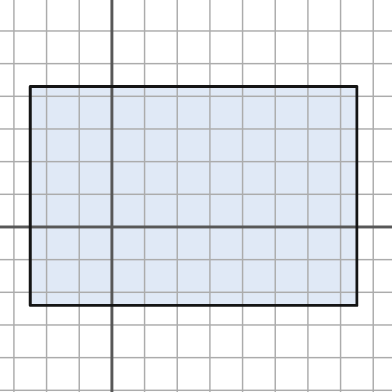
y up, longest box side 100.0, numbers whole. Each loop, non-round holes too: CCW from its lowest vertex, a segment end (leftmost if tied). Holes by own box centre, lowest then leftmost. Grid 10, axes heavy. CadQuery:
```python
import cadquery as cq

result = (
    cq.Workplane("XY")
    .moveTo(-25.0, -24.0)
    .lineTo(75.0, -24.0)
    .lineTo(75.0, 43.0)
    .lineTo(-25.0, 43.0)
    .close()
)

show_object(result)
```